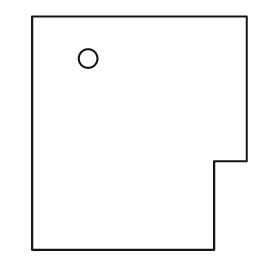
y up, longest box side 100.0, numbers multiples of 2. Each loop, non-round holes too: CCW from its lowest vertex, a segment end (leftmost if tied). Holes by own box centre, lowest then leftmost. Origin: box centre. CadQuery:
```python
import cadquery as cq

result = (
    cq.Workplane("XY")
    .moveTo(-46.0, -50.0)
    .lineTo(32.0, -50.0)
    .lineTo(32.0, -12.0)
    .lineTo(46.0, -12.0)
    .lineTo(46.0, 50.0)
    .lineTo(-46.0, 50.0)
    .close()
    .moveTo(-22.0, 32.0)
    .circle(4.0)
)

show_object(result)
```